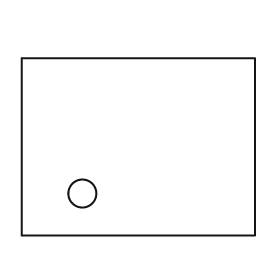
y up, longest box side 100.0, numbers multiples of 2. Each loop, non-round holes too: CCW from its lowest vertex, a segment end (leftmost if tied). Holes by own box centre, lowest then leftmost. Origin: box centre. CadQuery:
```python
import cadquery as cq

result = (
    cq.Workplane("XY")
    .moveTo(-50.0, -38.0)
    .lineTo(50.0, -38.0)
    .lineTo(50.0, 38.0)
    .lineTo(-50.0, 38.0)
    .close()
    .moveTo(-24.0, -20.0)
    .circle(6.0)
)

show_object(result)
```